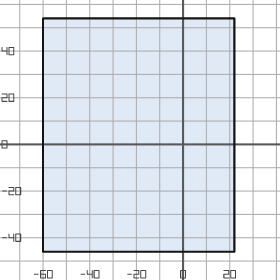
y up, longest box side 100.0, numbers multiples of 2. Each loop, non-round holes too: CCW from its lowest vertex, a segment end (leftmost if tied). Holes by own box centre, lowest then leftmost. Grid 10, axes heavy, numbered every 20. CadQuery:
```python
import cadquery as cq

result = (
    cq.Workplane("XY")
    .moveTo(-60.0, -46.0)
    .lineTo(22.0, -46.0)
    .lineTo(22.0, 54.0)
    .lineTo(-60.0, 54.0)
    .close()
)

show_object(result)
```